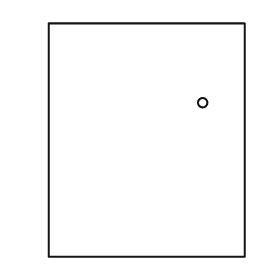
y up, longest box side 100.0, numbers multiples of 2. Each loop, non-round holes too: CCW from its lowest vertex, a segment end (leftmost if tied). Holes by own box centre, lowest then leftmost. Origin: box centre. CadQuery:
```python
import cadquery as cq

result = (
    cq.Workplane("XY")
    .moveTo(-42.0, -50.0)
    .lineTo(42.0, -50.0)
    .lineTo(42.0, 50.0)
    .lineTo(-42.0, 50.0)
    .close()
    .moveTo(24.0, 16.0)
    .circle(2.0)
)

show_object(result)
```